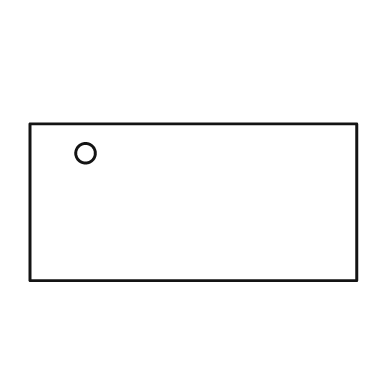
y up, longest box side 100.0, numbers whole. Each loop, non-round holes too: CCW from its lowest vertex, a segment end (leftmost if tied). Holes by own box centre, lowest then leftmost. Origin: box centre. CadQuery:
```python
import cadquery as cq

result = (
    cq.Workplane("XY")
    .moveTo(-50.0, -24.0)
    .lineTo(50.0, -24.0)
    .lineTo(50.0, 24.0)
    .lineTo(-50.0, 24.0)
    .close()
    .moveTo(-33.0, 15.0)
    .circle(3.0)
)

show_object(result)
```